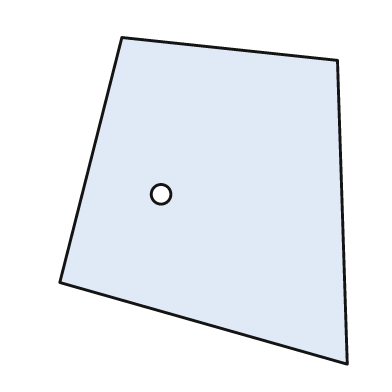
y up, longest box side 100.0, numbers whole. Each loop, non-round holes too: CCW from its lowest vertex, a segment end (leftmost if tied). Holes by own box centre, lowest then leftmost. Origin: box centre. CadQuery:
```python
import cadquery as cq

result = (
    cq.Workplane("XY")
    .moveTo(44.0, -50.0)
    .lineTo(41.0, 43.0)
    .lineTo(-25.0, 50.0)
    .lineTo(-44.0, -25.0)
    .close()
    .moveTo(-13.0, 2.0)
    .circle(3.0)
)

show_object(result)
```